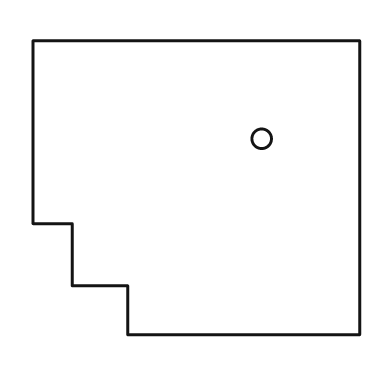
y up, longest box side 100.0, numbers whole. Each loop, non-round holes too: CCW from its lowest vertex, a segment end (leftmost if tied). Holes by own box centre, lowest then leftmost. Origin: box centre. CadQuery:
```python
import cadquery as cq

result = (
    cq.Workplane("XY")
    .moveTo(-21.0, -45.0)
    .lineTo(50.0, -45.0)
    .lineTo(50.0, 45.0)
    .lineTo(-50.0, 45.0)
    .lineTo(-50.0, -11.0)
    .lineTo(-38.0, -11.0)
    .lineTo(-38.0, -30.0)
    .lineTo(-21.0, -30.0)
    .close()
    .moveTo(20.0, 15.0)
    .circle(3.0)
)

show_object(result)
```